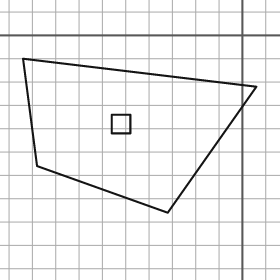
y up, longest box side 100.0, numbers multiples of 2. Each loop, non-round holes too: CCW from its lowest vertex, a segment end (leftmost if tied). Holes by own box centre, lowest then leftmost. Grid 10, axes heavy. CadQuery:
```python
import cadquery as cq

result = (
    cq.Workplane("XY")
    .moveTo(-32.0, -76.0)
    .lineTo(6.0, -22.0)
    .lineTo(-94.0, -10.0)
    .lineTo(-88.0, -56.0)
    .close()
    .moveTo(-56.0, -42.0)
    .lineTo(-48.0, -42.0)
    .lineTo(-48.0, -34.0)
    .lineTo(-56.0, -34.0)
    .close()
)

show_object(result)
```